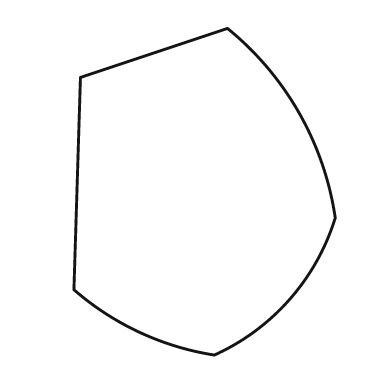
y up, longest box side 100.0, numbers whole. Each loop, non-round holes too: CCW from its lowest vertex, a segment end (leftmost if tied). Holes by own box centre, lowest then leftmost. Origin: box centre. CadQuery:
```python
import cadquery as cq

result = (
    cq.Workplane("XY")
    .moveTo(3.0, -50.0)
    .threePointArc((26.0, -33.0), (40.0, -8.0))
    .threePointArc((29.0, 24.0), (7.0, 50.0))
    .lineTo(-38.0, 35.0)
    .lineTo(-40.0, -30.0)
    .threePointArc((-20.0, -43.0), (3.0, -50.0))
    .close()
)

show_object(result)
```